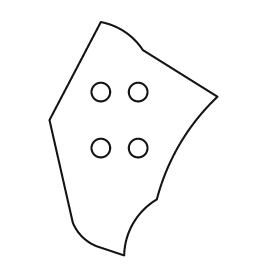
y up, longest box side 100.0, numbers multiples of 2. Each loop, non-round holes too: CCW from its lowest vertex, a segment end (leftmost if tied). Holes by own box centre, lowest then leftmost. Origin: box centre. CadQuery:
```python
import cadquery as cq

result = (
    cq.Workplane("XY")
    .moveTo(-4.0, -50.0)
    .threePointArc((0.0, -36.0), (10.0, -26.0))
    .threePointArc((20.0, -2.0), (36.0, 18.0))
    .lineTo(4.0, 38.0)
    .threePointArc((-4.0, 46.0), (-14.0, 50.0))
    .lineTo(-36.0, 8.0)
    .lineTo(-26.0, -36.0)
    .threePointArc((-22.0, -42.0), (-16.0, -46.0))
    .close()
    .moveTo(-14.0, -4.0)
    .circle(4.0)
    .moveTo(2.0, -4.0)
    .circle(4.0)
    .moveTo(-14.0, 20.0)
    .circle(4.0)
    .moveTo(2.0, 20.0)
    .circle(4.0)
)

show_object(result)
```